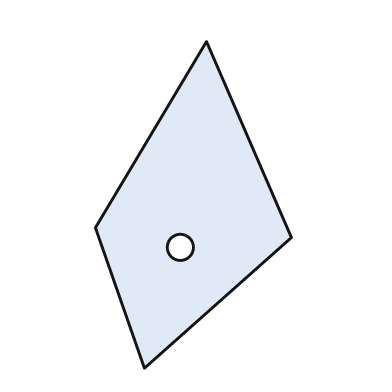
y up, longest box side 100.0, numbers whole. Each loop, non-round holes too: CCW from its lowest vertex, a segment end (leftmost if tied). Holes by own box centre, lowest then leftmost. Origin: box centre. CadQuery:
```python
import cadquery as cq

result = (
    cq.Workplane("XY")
    .moveTo(-15.0, -50.0)
    .lineTo(30.0, -10.0)
    .lineTo(4.0, 50.0)
    .lineTo(-30.0, -7.0)
    .close()
    .moveTo(-4.0, -13.0)
    .circle(4.0)
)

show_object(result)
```